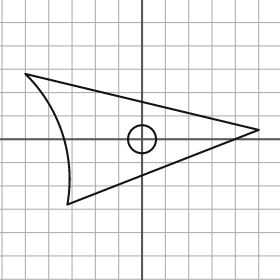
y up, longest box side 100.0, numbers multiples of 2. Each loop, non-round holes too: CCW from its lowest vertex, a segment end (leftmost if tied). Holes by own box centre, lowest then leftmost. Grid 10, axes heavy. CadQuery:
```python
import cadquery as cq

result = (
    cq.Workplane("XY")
    .moveTo(-32.0, -28.0)
    .lineTo(50.0, 4.0)
    .lineTo(-50.0, 28.0)
    .threePointArc((-34.0, 2.0), (-32.0, -28.0))
    .close()
    .moveTo(0.0, 0.0)
    .circle(6.0)
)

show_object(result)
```